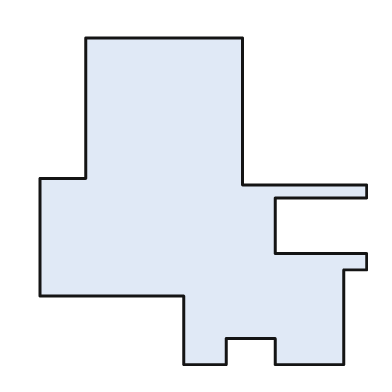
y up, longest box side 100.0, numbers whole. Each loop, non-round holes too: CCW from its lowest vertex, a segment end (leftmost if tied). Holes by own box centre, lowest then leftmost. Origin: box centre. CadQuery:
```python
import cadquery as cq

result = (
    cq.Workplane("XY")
    .moveTo(-6.0, -50.0)
    .lineTo(7.0, -50.0)
    .lineTo(7.0, -42.0)
    .lineTo(22.0, -42.0)
    .lineTo(22.0, -50.0)
    .lineTo(43.0, -50.0)
    .lineTo(43.0, -21.0)
    .lineTo(50.0, -21.0)
    .lineTo(50.0, -16.0)
    .lineTo(22.0, -16.0)
    .lineTo(22.0, 1.0)
    .lineTo(50.0, 1.0)
    .lineTo(50.0, 5.0)
    .lineTo(12.0, 5.0)
    .lineTo(12.0, 50.0)
    .lineTo(-36.0, 50.0)
    .lineTo(-36.0, 7.0)
    .lineTo(-50.0, 7.0)
    .lineTo(-50.0, -29.0)
    .lineTo(-6.0, -29.0)
    .close()
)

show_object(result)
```